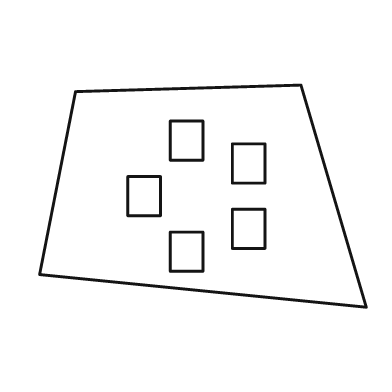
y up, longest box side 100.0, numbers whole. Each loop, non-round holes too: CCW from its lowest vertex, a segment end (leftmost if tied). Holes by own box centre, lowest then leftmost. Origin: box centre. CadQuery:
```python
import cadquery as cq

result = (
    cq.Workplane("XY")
    .moveTo(50.0, -34.0)
    .lineTo(30.0, 34.0)
    .lineTo(-39.0, 32.0)
    .lineTo(-50.0, -24.0)
    .close()
    .moveTo(-10.0, -23.0)
    .lineTo(0.0, -23.0)
    .lineTo(0.0, -11.0)
    .lineTo(-10.0, -11.0)
    .close()
    .moveTo(9.0, -16.0)
    .lineTo(19.0, -16.0)
    .lineTo(19.0, -4.0)
    .lineTo(9.0, -4.0)
    .close()
    .moveTo(-23.0, -6.0)
    .lineTo(-13.0, -6.0)
    .lineTo(-13.0, 6.0)
    .lineTo(-23.0, 6.0)
    .close()
    .moveTo(9.0, 4.0)
    .lineTo(19.0, 4.0)
    .lineTo(19.0, 16.0)
    .lineTo(9.0, 16.0)
    .close()
    .moveTo(-10.0, 11.0)
    .lineTo(0.0, 11.0)
    .lineTo(0.0, 23.0)
    .lineTo(-10.0, 23.0)
    .close()
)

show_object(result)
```